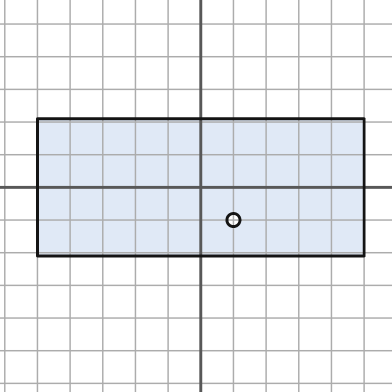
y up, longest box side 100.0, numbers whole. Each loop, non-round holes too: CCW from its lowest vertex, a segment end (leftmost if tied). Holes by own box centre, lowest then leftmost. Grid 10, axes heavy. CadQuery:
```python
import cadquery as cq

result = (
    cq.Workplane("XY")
    .moveTo(-50.0, -21.0)
    .lineTo(50.0, -21.0)
    .lineTo(50.0, 21.0)
    .lineTo(-50.0, 21.0)
    .close()
    .moveTo(10.0, -10.0)
    .circle(2.0)
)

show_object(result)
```